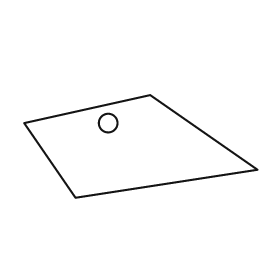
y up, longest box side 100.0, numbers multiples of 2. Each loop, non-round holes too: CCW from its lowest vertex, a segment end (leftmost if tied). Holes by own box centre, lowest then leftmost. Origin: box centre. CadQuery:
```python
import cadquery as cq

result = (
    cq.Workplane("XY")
    .moveTo(-28.0, -22.0)
    .lineTo(50.0, -10.0)
    .lineTo(4.0, 22.0)
    .lineTo(-50.0, 10.0)
    .close()
    .moveTo(-14.0, 10.0)
    .circle(4.0)
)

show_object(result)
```